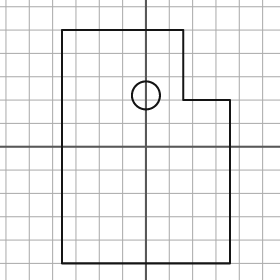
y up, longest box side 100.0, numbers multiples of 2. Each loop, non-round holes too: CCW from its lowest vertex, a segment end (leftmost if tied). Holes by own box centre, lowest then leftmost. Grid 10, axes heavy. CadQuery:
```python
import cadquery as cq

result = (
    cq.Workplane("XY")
    .moveTo(-36.0, -50.0)
    .lineTo(36.0, -50.0)
    .lineTo(36.0, 20.0)
    .lineTo(16.0, 20.0)
    .lineTo(16.0, 50.0)
    .lineTo(-36.0, 50.0)
    .close()
    .moveTo(0.0, 22.0)
    .circle(6.0)
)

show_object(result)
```